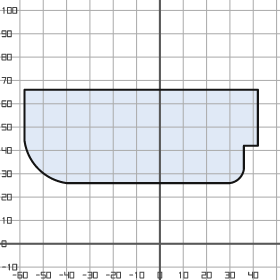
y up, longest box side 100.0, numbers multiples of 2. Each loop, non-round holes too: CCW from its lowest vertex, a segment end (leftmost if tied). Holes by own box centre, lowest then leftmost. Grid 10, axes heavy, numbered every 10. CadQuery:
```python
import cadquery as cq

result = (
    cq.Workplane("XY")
    .moveTo(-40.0, 26.0)
    .lineTo(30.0, 26.0)
    .threePointArc((34.0, 28.0), (36.0, 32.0))
    .lineTo(36.0, 42.0)
    .lineTo(42.0, 42.0)
    .lineTo(42.0, 66.0)
    .lineTo(-58.0, 66.0)
    .lineTo(-58.0, 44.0)
    .threePointArc((-52.0, 32.0), (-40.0, 26.0))
    .close()
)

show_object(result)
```